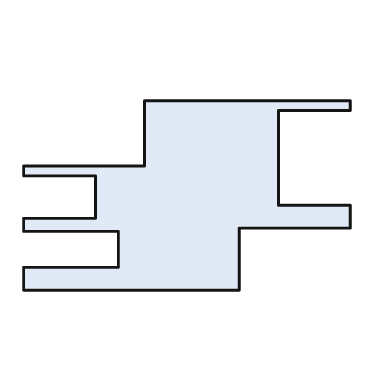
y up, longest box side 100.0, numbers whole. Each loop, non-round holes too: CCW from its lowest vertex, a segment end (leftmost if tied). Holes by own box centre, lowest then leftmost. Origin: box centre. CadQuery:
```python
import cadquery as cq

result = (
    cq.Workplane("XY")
    .moveTo(-50.0, -29.0)
    .lineTo(16.0, -29.0)
    .lineTo(16.0, -10.0)
    .lineTo(50.0, -10.0)
    .lineTo(50.0, -3.0)
    .lineTo(28.0, -3.0)
    .lineTo(28.0, 26.0)
    .lineTo(50.0, 26.0)
    .lineTo(50.0, 29.0)
    .lineTo(-13.0, 29.0)
    .lineTo(-13.0, 9.0)
    .lineTo(-50.0, 9.0)
    .lineTo(-50.0, 6.0)
    .lineTo(-28.0, 6.0)
    .lineTo(-28.0, -7.0)
    .lineTo(-50.0, -7.0)
    .lineTo(-50.0, -11.0)
    .lineTo(-21.0, -11.0)
    .lineTo(-21.0, -22.0)
    .lineTo(-50.0, -22.0)
    .close()
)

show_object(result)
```